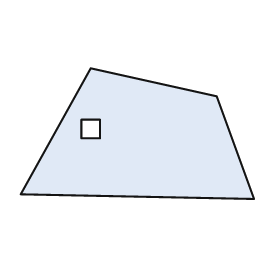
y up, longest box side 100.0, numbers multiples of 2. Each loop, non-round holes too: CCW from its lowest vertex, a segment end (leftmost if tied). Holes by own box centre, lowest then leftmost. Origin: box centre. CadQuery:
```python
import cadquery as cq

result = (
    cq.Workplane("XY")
    .moveTo(50.0, -28.0)
    .lineTo(34.0, 16.0)
    .lineTo(-20.0, 28.0)
    .lineTo(-50.0, -26.0)
    .close()
    .moveTo(-24.0, -2.0)
    .lineTo(-16.0, -2.0)
    .lineTo(-16.0, 6.0)
    .lineTo(-24.0, 6.0)
    .close()
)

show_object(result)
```